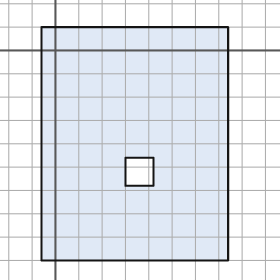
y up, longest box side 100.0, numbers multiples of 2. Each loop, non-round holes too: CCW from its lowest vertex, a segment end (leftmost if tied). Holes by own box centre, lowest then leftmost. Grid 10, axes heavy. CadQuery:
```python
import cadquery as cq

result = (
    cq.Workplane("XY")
    .moveTo(-6.0, -90.0)
    .lineTo(74.0, -90.0)
    .lineTo(74.0, 10.0)
    .lineTo(-6.0, 10.0)
    .close()
    .moveTo(30.0, -58.0)
    .lineTo(42.0, -58.0)
    .lineTo(42.0, -46.0)
    .lineTo(30.0, -46.0)
    .close()
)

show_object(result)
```